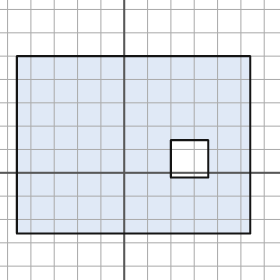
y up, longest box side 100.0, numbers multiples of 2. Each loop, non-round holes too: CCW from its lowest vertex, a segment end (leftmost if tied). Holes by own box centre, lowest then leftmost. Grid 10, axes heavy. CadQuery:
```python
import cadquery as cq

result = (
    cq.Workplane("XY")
    .moveTo(-46.0, -26.0)
    .lineTo(54.0, -26.0)
    .lineTo(54.0, 50.0)
    .lineTo(-46.0, 50.0)
    .close()
    .moveTo(20.0, -2.0)
    .lineTo(36.0, -2.0)
    .lineTo(36.0, 14.0)
    .lineTo(20.0, 14.0)
    .close()
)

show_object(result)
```